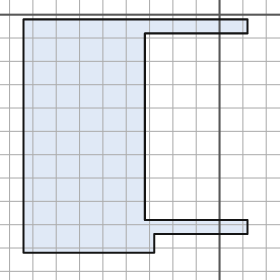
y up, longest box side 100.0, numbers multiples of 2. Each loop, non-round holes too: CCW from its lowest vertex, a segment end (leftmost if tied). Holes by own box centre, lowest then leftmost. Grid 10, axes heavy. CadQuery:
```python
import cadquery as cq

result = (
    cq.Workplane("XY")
    .moveTo(-84.0, -102.0)
    .lineTo(-28.0, -102.0)
    .lineTo(-28.0, -94.0)
    .lineTo(12.0, -94.0)
    .lineTo(12.0, -88.0)
    .lineTo(-32.0, -88.0)
    .lineTo(-32.0, -8.0)
    .lineTo(12.0, -8.0)
    .lineTo(12.0, -2.0)
    .lineTo(-84.0, -2.0)
    .close()
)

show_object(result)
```